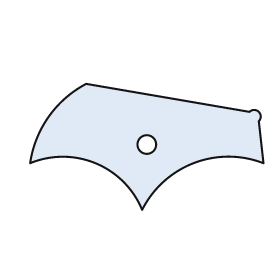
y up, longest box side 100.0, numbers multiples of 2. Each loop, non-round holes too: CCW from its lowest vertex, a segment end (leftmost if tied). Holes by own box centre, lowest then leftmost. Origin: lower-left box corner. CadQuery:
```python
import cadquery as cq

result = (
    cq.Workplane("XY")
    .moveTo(48.0, 0.0)
    .threePointArc((70.0, 20.0), (100.0, 20.0))
    .lineTo(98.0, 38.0)
    .threePointArc((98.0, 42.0), (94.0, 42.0))
    .lineTo(24.0, 54.0)
    .threePointArc((8.0, 40.0), (0.0, 20.0))
    .threePointArc((28.0, 20.0), (48.0, 0.0))
    .close()
    .moveTo(50.0, 28.0)
    .circle(4.0)
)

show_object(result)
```